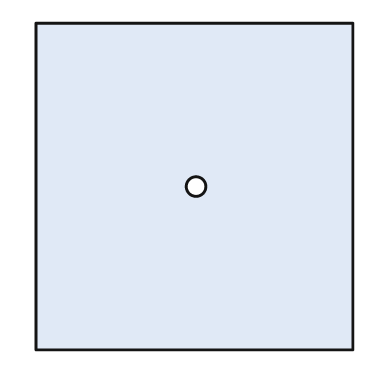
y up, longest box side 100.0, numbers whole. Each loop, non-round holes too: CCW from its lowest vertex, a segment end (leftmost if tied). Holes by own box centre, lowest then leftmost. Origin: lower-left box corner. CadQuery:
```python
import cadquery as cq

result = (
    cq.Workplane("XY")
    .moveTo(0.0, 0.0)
    .lineTo(97.0, 0.0)
    .lineTo(97.0, 100.0)
    .lineTo(0.0, 100.0)
    .close()
    .moveTo(49.0, 50.0)
    .circle(3.0)
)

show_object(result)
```